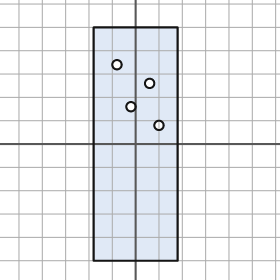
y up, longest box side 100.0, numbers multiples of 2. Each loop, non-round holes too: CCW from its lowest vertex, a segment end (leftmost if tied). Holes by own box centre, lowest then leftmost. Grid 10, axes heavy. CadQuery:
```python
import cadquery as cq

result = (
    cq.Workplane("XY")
    .moveTo(-18.0, -50.0)
    .lineTo(18.0, -50.0)
    .lineTo(18.0, 50.0)
    .lineTo(-18.0, 50.0)
    .close()
    .moveTo(10.0, 8.0)
    .circle(2.0)
    .moveTo(-2.0, 16.0)
    .circle(2.0)
    .moveTo(6.0, 26.0)
    .circle(2.0)
    .moveTo(-8.0, 34.0)
    .circle(2.0)
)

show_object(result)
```